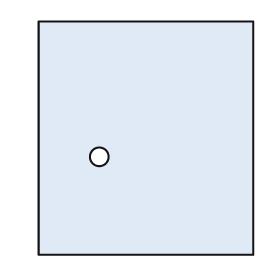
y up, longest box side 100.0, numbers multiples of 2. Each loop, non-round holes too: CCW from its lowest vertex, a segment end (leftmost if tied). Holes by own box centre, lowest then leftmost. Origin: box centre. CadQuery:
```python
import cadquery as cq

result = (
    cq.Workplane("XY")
    .moveTo(-46.0, -50.0)
    .lineTo(46.0, -50.0)
    .lineTo(46.0, 50.0)
    .lineTo(-46.0, 50.0)
    .close()
    .moveTo(-20.0, -8.0)
    .circle(4.0)
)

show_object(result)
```